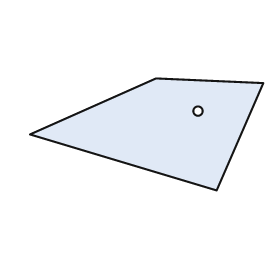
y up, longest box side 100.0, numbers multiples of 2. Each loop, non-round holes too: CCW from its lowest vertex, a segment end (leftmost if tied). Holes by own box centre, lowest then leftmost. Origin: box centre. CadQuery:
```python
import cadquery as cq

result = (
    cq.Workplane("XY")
    .moveTo(30.0, -24.0)
    .lineTo(50.0, 22.0)
    .lineTo(4.0, 24.0)
    .lineTo(-50.0, 0.0)
    .close()
    .moveTo(22.0, 10.0)
    .circle(2.0)
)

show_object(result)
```